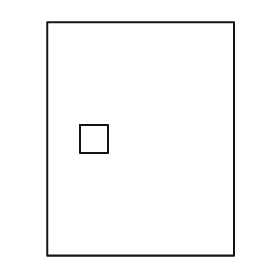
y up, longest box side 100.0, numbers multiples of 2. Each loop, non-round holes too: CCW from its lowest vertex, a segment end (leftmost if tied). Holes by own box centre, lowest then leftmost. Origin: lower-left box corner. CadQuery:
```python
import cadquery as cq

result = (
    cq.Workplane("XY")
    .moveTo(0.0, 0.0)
    .lineTo(80.0, 0.0)
    .lineTo(80.0, 100.0)
    .lineTo(0.0, 100.0)
    .close()
    .moveTo(14.0, 44.0)
    .lineTo(26.0, 44.0)
    .lineTo(26.0, 56.0)
    .lineTo(14.0, 56.0)
    .close()
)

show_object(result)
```